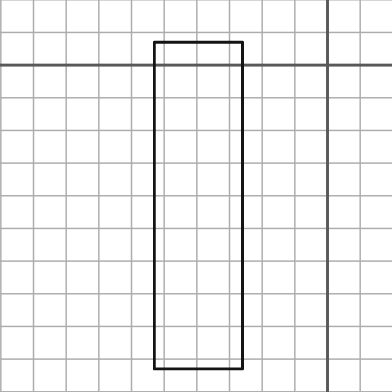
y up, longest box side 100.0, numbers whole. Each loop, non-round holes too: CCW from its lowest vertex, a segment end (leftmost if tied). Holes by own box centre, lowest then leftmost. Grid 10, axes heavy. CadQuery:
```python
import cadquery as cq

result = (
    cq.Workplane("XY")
    .moveTo(-53.0, -93.0)
    .lineTo(-26.0, -93.0)
    .lineTo(-26.0, 7.0)
    .lineTo(-53.0, 7.0)
    .close()
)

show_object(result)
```